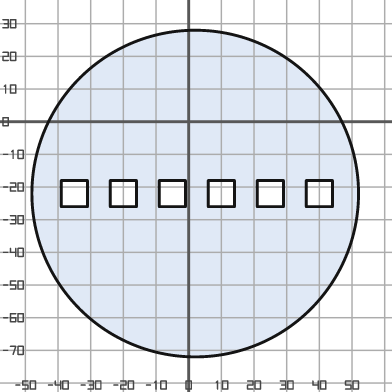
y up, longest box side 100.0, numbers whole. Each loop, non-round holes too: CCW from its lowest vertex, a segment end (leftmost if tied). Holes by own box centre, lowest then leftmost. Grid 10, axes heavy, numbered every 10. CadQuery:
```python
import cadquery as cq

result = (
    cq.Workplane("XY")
    .moveTo(2.0, -22.0)
    .circle(50.0)
    .moveTo(-39.0, -26.0)
    .lineTo(-31.0, -26.0)
    .lineTo(-31.0, -18.0)
    .lineTo(-39.0, -18.0)
    .close()
    .moveTo(-24.0, -26.0)
    .lineTo(-16.0, -26.0)
    .lineTo(-16.0, -18.0)
    .lineTo(-24.0, -18.0)
    .close()
    .moveTo(-9.0, -26.0)
    .lineTo(-1.0, -26.0)
    .lineTo(-1.0, -18.0)
    .lineTo(-9.0, -18.0)
    .close()
    .moveTo(6.0, -26.0)
    .lineTo(14.0, -26.0)
    .lineTo(14.0, -18.0)
    .lineTo(6.0, -18.0)
    .close()
    .moveTo(21.0, -26.0)
    .lineTo(29.0, -26.0)
    .lineTo(29.0, -18.0)
    .lineTo(21.0, -18.0)
    .close()
    .moveTo(36.0, -26.0)
    .lineTo(44.0, -26.0)
    .lineTo(44.0, -18.0)
    .lineTo(36.0, -18.0)
    .close()
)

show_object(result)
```